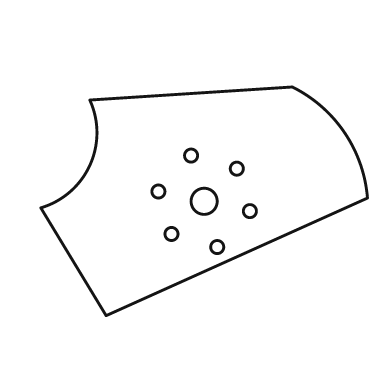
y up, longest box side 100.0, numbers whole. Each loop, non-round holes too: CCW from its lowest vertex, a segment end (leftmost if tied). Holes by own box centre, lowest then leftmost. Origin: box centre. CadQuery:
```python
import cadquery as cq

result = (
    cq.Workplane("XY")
    .moveTo(-30.0, -35.0)
    .lineTo(50.0, 1.0)
    .threePointArc((43.0, 21.0), (27.0, 35.0))
    .lineTo(-35.0, 31.0)
    .threePointArc((-35.0, 11.0), (-50.0, -2.0))
    .close()
    .moveTo(4.0, -14.0)
    .circle(2.0)
    .moveTo(-10.0, -10.0)
    .circle(2.0)
    .moveTo(14.0, -3.0)
    .circle(2.0)
    .moveTo(0.0, 0.0)
    .circle(4.0)
    .moveTo(-14.0, 3.0)
    .circle(2.0)
    .moveTo(10.0, 10.0)
    .circle(2.0)
    .moveTo(-4.0, 14.0)
    .circle(2.0)
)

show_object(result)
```